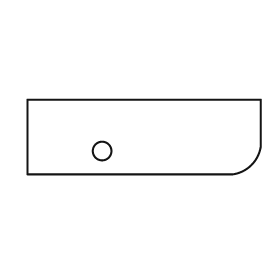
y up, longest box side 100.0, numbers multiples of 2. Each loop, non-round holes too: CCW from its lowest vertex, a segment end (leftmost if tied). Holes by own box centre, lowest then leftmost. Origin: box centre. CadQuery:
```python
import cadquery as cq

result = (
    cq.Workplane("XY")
    .moveTo(-50.0, -16.0)
    .lineTo(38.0, -16.0)
    .threePointArc((46.0, -12.0), (50.0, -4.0))
    .lineTo(50.0, 16.0)
    .lineTo(-50.0, 16.0)
    .close()
    .moveTo(-18.0, -6.0)
    .circle(4.0)
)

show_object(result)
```